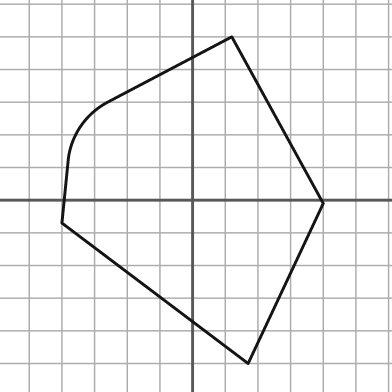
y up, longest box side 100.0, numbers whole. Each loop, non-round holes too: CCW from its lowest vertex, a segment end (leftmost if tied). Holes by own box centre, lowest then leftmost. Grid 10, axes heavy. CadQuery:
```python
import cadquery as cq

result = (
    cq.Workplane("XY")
    .moveTo(17.0, -50.0)
    .lineTo(40.0, -1.0)
    .lineTo(12.0, 50.0)
    .lineTo(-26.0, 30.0)
    .threePointArc((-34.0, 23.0), (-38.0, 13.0))
    .lineTo(-40.0, -7.0)
    .close()
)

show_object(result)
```